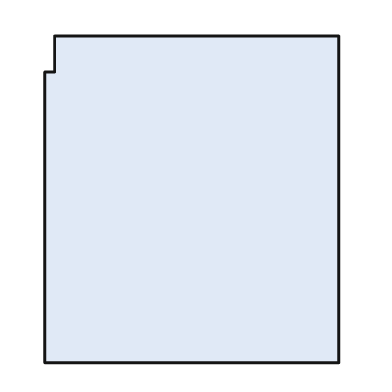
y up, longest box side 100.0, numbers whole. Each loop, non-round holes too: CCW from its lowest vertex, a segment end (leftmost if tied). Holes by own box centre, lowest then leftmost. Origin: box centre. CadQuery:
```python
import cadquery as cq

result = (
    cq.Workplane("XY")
    .moveTo(-45.0, -50.0)
    .lineTo(45.0, -50.0)
    .lineTo(45.0, 50.0)
    .lineTo(-42.0, 50.0)
    .lineTo(-42.0, 39.0)
    .lineTo(-45.0, 39.0)
    .close()
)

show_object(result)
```